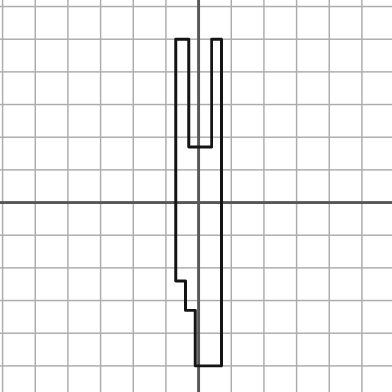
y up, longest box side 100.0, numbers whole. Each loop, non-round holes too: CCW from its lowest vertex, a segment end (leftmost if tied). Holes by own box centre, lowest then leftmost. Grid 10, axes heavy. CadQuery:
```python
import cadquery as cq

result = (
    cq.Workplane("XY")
    .moveTo(-1.0, -50.0)
    .lineTo(7.0, -50.0)
    .lineTo(7.0, 50.0)
    .lineTo(4.0, 50.0)
    .lineTo(4.0, 17.0)
    .lineTo(-3.0, 17.0)
    .lineTo(-3.0, 50.0)
    .lineTo(-7.0, 50.0)
    .lineTo(-7.0, -24.0)
    .lineTo(-4.0, -24.0)
    .lineTo(-4.0, -33.0)
    .lineTo(-1.0, -33.0)
    .close()
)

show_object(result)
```